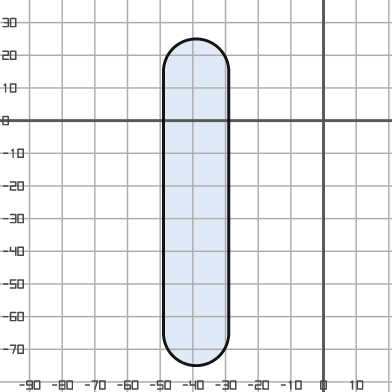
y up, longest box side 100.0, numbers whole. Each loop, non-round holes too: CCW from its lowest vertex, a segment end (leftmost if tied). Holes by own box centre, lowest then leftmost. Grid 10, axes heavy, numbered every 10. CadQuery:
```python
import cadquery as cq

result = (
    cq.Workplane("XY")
    .moveTo(-49.0, -65.0)
    .threePointArc((-39.0, -75.0), (-29.0, -65.0))
    .lineTo(-29.0, 15.0)
    .threePointArc((-39.0, 25.0), (-49.0, 15.0))
    .close()
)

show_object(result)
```